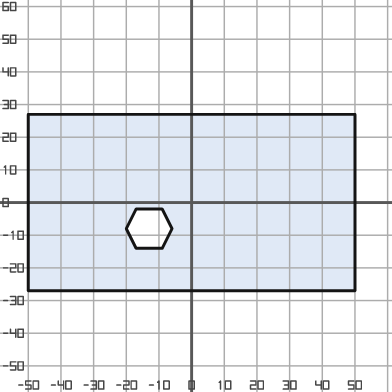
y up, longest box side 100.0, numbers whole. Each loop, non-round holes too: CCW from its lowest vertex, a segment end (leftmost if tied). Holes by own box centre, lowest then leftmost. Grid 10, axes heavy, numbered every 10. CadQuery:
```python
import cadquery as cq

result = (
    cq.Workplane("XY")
    .moveTo(-50.0, -27.0)
    .lineTo(50.0, -27.0)
    .lineTo(50.0, 27.0)
    .lineTo(-50.0, 27.0)
    .close()
    .moveTo(-17.0, -14.0)
    .lineTo(-9.0, -14.0)
    .lineTo(-6.0, -8.0)
    .lineTo(-9.0, -2.0)
    .lineTo(-17.0, -2.0)
    .lineTo(-20.0, -8.0)
    .close()
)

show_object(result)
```